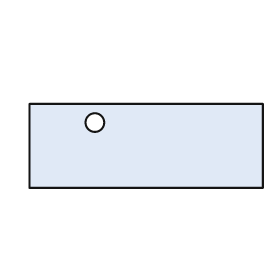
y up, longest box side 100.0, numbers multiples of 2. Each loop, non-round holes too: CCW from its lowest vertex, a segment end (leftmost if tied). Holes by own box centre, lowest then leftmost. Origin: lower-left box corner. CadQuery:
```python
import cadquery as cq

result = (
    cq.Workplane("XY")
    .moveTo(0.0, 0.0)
    .lineTo(100.0, 0.0)
    .lineTo(100.0, 36.0)
    .lineTo(0.0, 36.0)
    .close()
    .moveTo(28.0, 28.0)
    .circle(4.0)
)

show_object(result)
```